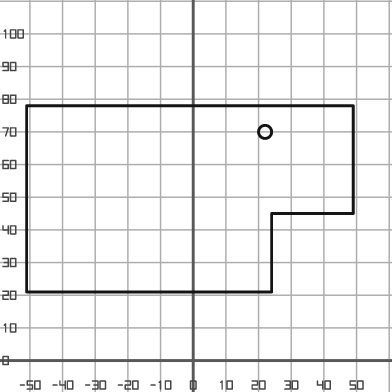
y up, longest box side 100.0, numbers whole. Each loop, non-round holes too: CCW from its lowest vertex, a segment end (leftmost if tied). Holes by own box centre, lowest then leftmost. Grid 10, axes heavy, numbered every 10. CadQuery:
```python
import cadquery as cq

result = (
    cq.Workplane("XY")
    .moveTo(-51.0, 21.0)
    .lineTo(24.0, 21.0)
    .lineTo(24.0, 45.0)
    .lineTo(49.0, 45.0)
    .lineTo(49.0, 78.0)
    .lineTo(-51.0, 78.0)
    .close()
    .moveTo(22.0, 70.0)
    .circle(2.0)
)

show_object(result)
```